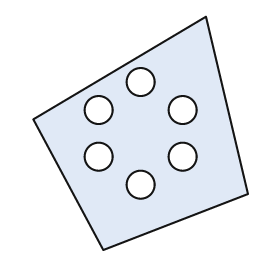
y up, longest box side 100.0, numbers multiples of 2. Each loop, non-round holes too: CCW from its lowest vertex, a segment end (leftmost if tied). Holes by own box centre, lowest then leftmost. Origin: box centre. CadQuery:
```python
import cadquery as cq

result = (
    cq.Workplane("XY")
    .moveTo(-16.0, -50.0)
    .lineTo(46.0, -26.0)
    .lineTo(28.0, 50.0)
    .lineTo(-46.0, 6.0)
    .close()
    .moveTo(0.0, -22.0)
    .circle(6.0)
    .moveTo(-18.0, -10.0)
    .circle(6.0)
    .moveTo(18.0, -10.0)
    .circle(6.0)
    .moveTo(-18.0, 10.0)
    .circle(6.0)
    .moveTo(18.0, 10.0)
    .circle(6.0)
    .moveTo(0.0, 22.0)
    .circle(6.0)
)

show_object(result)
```